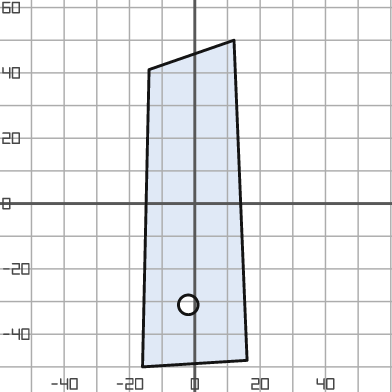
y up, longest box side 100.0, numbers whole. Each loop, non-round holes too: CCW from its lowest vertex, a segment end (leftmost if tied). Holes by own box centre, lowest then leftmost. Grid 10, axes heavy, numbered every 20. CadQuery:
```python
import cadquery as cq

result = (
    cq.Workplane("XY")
    .moveTo(-16.0, -50.0)
    .lineTo(16.0, -48.0)
    .lineTo(12.0, 50.0)
    .lineTo(-14.0, 41.0)
    .close()
    .moveTo(-2.0, -31.0)
    .circle(3.0)
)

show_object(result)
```